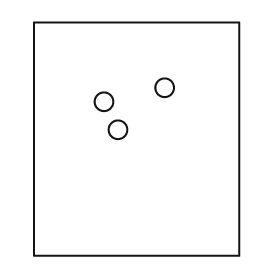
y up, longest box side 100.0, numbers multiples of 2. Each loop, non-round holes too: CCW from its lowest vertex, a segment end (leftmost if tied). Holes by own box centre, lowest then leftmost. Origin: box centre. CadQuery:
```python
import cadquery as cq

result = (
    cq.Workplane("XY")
    .moveTo(-44.0, -50.0)
    .lineTo(44.0, -50.0)
    .lineTo(44.0, 50.0)
    .lineTo(-44.0, 50.0)
    .close()
    .moveTo(-8.0, 4.0)
    .circle(4.0)
    .moveTo(-14.0, 16.0)
    .circle(4.0)
    .moveTo(12.0, 22.0)
    .circle(4.0)
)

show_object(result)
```